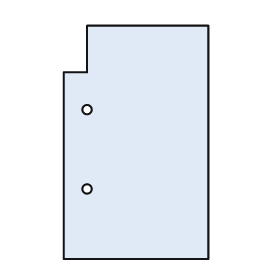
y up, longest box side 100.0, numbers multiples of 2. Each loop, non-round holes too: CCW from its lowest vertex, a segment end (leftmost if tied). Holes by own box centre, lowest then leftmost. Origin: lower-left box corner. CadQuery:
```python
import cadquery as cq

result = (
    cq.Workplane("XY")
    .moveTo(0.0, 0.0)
    .lineTo(62.0, 0.0)
    .lineTo(62.0, 100.0)
    .lineTo(10.0, 100.0)
    .lineTo(10.0, 80.0)
    .lineTo(0.0, 80.0)
    .close()
    .moveTo(10.0, 30.0)
    .circle(2.0)
    .moveTo(10.0, 64.0)
    .circle(2.0)
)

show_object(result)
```